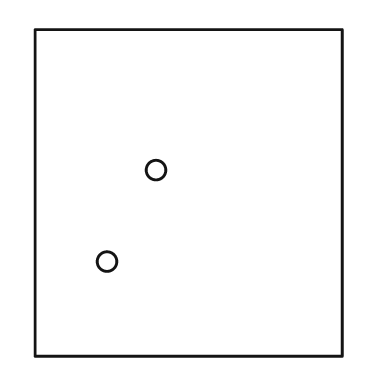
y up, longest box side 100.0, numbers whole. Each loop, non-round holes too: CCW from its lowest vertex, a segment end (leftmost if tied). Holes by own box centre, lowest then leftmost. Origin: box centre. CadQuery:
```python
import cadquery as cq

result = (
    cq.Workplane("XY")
    .moveTo(-47.0, -50.0)
    .lineTo(47.0, -50.0)
    .lineTo(47.0, 50.0)
    .lineTo(-47.0, 50.0)
    .close()
    .moveTo(-25.0, -21.0)
    .circle(3.0)
    .moveTo(-10.0, 7.0)
    .circle(3.0)
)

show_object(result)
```